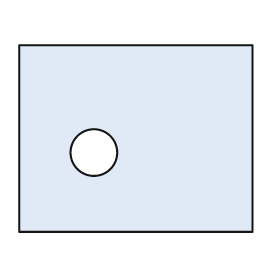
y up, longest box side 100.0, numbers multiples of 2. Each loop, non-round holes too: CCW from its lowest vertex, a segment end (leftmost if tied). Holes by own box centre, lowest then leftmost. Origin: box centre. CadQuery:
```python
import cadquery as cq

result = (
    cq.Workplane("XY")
    .moveTo(-50.0, -40.0)
    .lineTo(50.0, -40.0)
    .lineTo(50.0, 40.0)
    .lineTo(-50.0, 40.0)
    .close()
    .moveTo(-18.0, -6.0)
    .circle(10.0)
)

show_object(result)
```